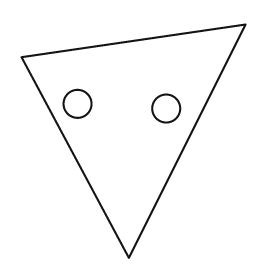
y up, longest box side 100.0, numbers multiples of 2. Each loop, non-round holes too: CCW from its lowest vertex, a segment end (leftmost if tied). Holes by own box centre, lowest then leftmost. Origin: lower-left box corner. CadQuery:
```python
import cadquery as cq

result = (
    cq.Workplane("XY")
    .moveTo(46.0, 0.0)
    .lineTo(96.0, 100.0)
    .lineTo(0.0, 86.0)
    .close()
    .moveTo(62.0, 64.0)
    .circle(6.0)
    .moveTo(24.0, 66.0)
    .circle(6.0)
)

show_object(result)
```